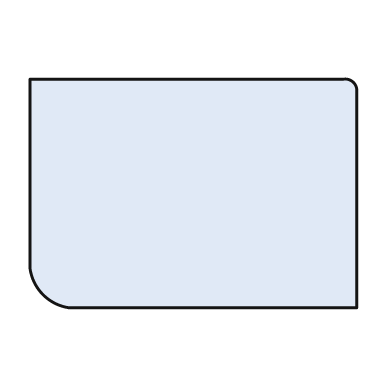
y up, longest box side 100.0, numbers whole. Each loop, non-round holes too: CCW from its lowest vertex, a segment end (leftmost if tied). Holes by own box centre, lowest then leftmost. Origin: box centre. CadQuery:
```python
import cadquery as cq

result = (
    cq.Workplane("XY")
    .moveTo(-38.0, -35.0)
    .lineTo(50.0, -35.0)
    .lineTo(50.0, 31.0)
    .threePointArc((49.0, 34.0), (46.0, 35.0))
    .lineTo(-50.0, 35.0)
    .lineTo(-50.0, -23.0)
    .threePointArc((-46.0, -31.0), (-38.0, -35.0))
    .close()
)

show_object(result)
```